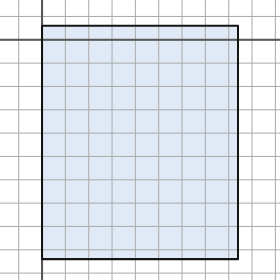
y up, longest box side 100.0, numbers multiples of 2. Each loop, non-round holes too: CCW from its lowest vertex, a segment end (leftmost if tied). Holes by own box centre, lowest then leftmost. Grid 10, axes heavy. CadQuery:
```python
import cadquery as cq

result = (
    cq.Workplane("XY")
    .moveTo(0.0, -94.0)
    .lineTo(84.0, -94.0)
    .lineTo(84.0, 6.0)
    .lineTo(0.0, 6.0)
    .close()
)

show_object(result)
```